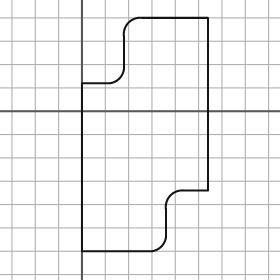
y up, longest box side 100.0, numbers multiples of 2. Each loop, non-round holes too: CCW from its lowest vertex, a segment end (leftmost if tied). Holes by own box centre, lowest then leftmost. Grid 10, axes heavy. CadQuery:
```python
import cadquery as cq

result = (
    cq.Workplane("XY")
    .moveTo(0.0, -60.0)
    .lineTo(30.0, -60.0)
    .threePointArc((34.0, -58.0), (36.0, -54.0))
    .lineTo(36.0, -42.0)
    .threePointArc((38.0, -36.0), (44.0, -34.0))
    .lineTo(54.0, -34.0)
    .lineTo(54.0, 40.0)
    .lineTo(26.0, 40.0)
    .threePointArc((20.0, 38.0), (18.0, 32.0))
    .lineTo(18.0, 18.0)
    .threePointArc((16.0, 14.0), (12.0, 12.0))
    .lineTo(0.0, 12.0)
    .close()
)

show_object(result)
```